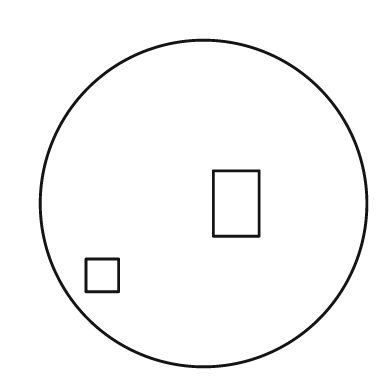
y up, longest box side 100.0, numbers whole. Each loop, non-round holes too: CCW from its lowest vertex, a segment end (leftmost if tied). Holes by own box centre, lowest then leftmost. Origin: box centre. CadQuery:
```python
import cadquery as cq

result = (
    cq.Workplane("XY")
    .moveTo(0.0, 0.0)
    .circle(50.0)
    .moveTo(-36.0, -27.0)
    .lineTo(-26.0, -27.0)
    .lineTo(-26.0, -17.0)
    .lineTo(-36.0, -17.0)
    .close()
    .moveTo(3.0, -10.0)
    .lineTo(17.0, -10.0)
    .lineTo(17.0, 10.0)
    .lineTo(3.0, 10.0)
    .close()
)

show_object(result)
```